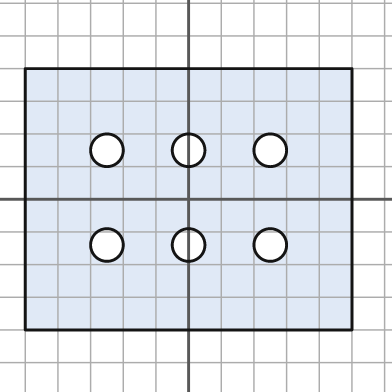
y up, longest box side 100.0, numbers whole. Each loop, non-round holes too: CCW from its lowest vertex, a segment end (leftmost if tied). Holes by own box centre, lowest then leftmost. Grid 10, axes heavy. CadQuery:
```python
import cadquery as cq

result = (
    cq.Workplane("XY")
    .moveTo(-50.0, -40.0)
    .lineTo(50.0, -40.0)
    .lineTo(50.0, 40.0)
    .lineTo(-50.0, 40.0)
    .close()
    .moveTo(-25.0, -14.0)
    .circle(5.0)
    .moveTo(0.0, -14.0)
    .circle(5.0)
    .moveTo(25.0, -14.0)
    .circle(5.0)
    .moveTo(-25.0, 15.0)
    .circle(5.0)
    .moveTo(0.0, 15.0)
    .circle(5.0)
    .moveTo(25.0, 15.0)
    .circle(5.0)
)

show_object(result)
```